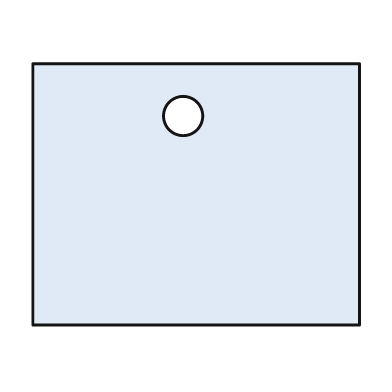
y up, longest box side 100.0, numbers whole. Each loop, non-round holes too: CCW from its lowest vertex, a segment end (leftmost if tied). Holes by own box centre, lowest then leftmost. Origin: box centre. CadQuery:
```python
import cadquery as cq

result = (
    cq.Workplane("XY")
    .moveTo(-50.0, -40.0)
    .lineTo(50.0, -40.0)
    .lineTo(50.0, 40.0)
    .lineTo(-50.0, 40.0)
    .close()
    .moveTo(-4.0, 24.0)
    .circle(6.0)
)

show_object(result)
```